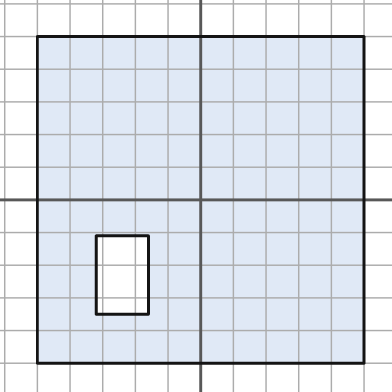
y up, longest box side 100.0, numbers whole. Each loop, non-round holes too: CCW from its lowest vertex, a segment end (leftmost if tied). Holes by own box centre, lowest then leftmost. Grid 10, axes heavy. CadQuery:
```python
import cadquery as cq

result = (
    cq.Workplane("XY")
    .moveTo(-50.0, -50.0)
    .lineTo(50.0, -50.0)
    .lineTo(50.0, 50.0)
    .lineTo(-50.0, 50.0)
    .close()
    .moveTo(-32.0, -35.0)
    .lineTo(-16.0, -35.0)
    .lineTo(-16.0, -11.0)
    .lineTo(-32.0, -11.0)
    .close()
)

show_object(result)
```